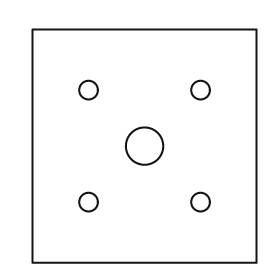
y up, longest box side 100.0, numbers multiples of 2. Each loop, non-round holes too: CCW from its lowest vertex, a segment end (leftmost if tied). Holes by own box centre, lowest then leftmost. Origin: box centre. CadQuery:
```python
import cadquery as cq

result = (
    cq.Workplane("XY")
    .moveTo(-48.0, -50.0)
    .lineTo(48.0, -50.0)
    .lineTo(48.0, 50.0)
    .lineTo(-48.0, 50.0)
    .close()
    .moveTo(-24.0, -24.0)
    .circle(4.0)
    .moveTo(24.0, -24.0)
    .circle(4.0)
    .moveTo(0.0, 0.0)
    .circle(8.0)
    .moveTo(-24.0, 24.0)
    .circle(4.0)
    .moveTo(24.0, 24.0)
    .circle(4.0)
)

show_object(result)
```